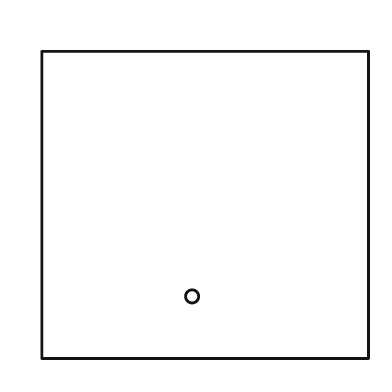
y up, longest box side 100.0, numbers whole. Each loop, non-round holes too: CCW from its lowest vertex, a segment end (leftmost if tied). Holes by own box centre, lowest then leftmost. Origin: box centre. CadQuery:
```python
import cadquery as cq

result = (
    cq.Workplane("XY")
    .moveTo(-50.0, -47.0)
    .lineTo(50.0, -47.0)
    .lineTo(50.0, 47.0)
    .lineTo(-50.0, 47.0)
    .close()
    .moveTo(-4.0, -28.0)
    .circle(2.0)
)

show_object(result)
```